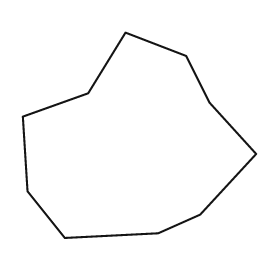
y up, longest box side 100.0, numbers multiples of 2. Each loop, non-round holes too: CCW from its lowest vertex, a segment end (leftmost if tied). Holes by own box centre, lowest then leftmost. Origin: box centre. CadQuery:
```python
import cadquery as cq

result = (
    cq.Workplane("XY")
    .moveTo(-32.0, -44.0)
    .lineTo(8.0, -42.0)
    .lineTo(26.0, -34.0)
    .lineTo(50.0, -8.0)
    .lineTo(30.0, 14.0)
    .lineTo(20.0, 34.0)
    .lineTo(-6.0, 44.0)
    .lineTo(-22.0, 18.0)
    .lineTo(-50.0, 8.0)
    .lineTo(-48.0, -24.0)
    .close()
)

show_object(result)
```